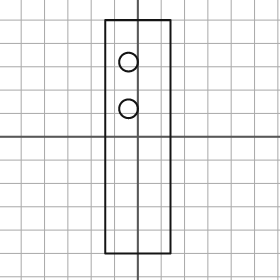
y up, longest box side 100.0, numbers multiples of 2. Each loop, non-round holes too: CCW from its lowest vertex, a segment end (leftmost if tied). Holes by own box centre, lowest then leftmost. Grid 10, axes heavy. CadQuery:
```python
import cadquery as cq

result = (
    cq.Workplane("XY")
    .moveTo(-14.0, -50.0)
    .lineTo(14.0, -50.0)
    .lineTo(14.0, 50.0)
    .lineTo(-14.0, 50.0)
    .close()
    .moveTo(-4.0, 12.0)
    .circle(4.0)
    .moveTo(-4.0, 32.0)
    .circle(4.0)
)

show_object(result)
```